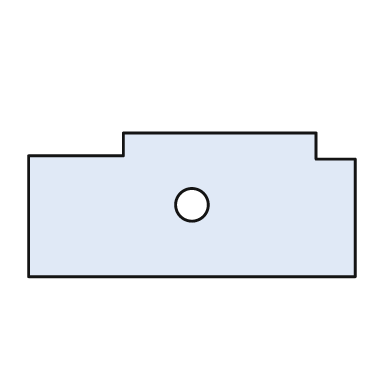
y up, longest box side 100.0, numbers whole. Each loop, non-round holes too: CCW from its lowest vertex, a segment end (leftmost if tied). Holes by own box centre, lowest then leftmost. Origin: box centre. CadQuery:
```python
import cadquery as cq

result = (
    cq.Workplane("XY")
    .moveTo(-50.0, -22.0)
    .lineTo(50.0, -22.0)
    .lineTo(50.0, 14.0)
    .lineTo(38.0, 14.0)
    .lineTo(38.0, 22.0)
    .lineTo(-21.0, 22.0)
    .lineTo(-21.0, 15.0)
    .lineTo(-50.0, 15.0)
    .close()
    .moveTo(0.0, 0.0)
    .circle(5.0)
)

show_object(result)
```